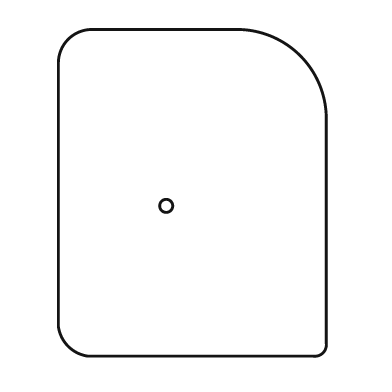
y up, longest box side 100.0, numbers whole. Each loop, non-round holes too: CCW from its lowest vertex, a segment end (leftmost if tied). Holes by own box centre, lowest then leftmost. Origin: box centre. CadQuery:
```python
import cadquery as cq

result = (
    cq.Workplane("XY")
    .moveTo(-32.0, -50.0)
    .lineTo(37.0, -50.0)
    .threePointArc((40.0, -49.0), (41.0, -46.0))
    .lineTo(41.0, 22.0)
    .threePointArc((33.0, 42.0), (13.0, 50.0))
    .lineTo(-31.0, 50.0)
    .threePointArc((-38.0, 47.0), (-41.0, 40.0))
    .lineTo(-41.0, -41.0)
    .threePointArc((-38.0, -47.0), (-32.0, -50.0))
    .close()
    .moveTo(-8.0, -4.0)
    .circle(2.0)
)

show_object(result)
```